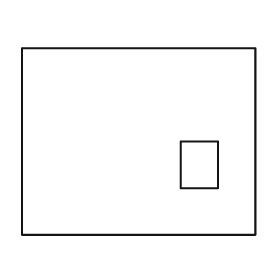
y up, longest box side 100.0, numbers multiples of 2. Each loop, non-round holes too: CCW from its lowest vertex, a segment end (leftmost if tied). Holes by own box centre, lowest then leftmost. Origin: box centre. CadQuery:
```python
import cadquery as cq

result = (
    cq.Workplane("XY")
    .moveTo(-50.0, -40.0)
    .lineTo(50.0, -40.0)
    .lineTo(50.0, 40.0)
    .lineTo(-50.0, 40.0)
    .close()
    .moveTo(18.0, -20.0)
    .lineTo(34.0, -20.0)
    .lineTo(34.0, 0.0)
    .lineTo(18.0, 0.0)
    .close()
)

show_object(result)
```